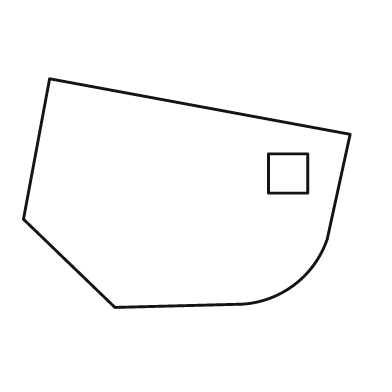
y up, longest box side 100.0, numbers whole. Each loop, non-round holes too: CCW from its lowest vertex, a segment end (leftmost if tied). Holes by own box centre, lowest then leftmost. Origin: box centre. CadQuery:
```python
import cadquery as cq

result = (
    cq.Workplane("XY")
    .moveTo(-22.0, -35.0)
    .lineTo(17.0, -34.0)
    .threePointArc((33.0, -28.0), (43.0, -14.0))
    .lineTo(50.0, 18.0)
    .lineTo(-42.0, 35.0)
    .lineTo(-50.0, -8.0)
    .close()
    .moveTo(25.0, 0.0)
    .lineTo(37.0, 0.0)
    .lineTo(37.0, 12.0)
    .lineTo(25.0, 12.0)
    .close()
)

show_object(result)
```